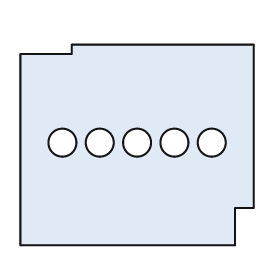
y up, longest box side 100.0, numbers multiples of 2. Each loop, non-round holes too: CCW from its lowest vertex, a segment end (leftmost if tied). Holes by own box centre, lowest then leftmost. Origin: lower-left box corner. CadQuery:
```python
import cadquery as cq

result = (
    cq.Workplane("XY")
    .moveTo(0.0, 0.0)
    .lineTo(92.0, 0.0)
    .lineTo(92.0, 16.0)
    .lineTo(100.0, 16.0)
    .lineTo(100.0, 86.0)
    .lineTo(22.0, 86.0)
    .lineTo(22.0, 82.0)
    .lineTo(0.0, 82.0)
    .close()
    .moveTo(18.0, 44.0)
    .circle(6.0)
    .moveTo(34.0, 44.0)
    .circle(6.0)
    .moveTo(50.0, 44.0)
    .circle(6.0)
    .moveTo(66.0, 44.0)
    .circle(6.0)
    .moveTo(82.0, 44.0)
    .circle(6.0)
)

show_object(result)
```